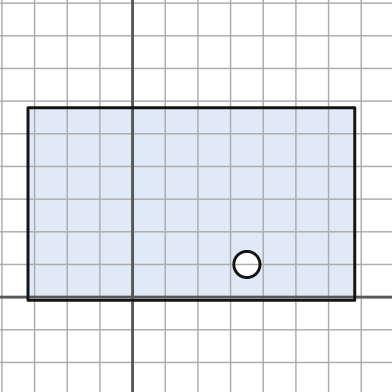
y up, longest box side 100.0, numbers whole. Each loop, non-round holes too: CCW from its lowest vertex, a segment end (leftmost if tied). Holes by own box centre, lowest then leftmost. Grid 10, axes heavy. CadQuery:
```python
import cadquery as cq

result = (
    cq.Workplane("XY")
    .moveTo(-32.0, -1.0)
    .lineTo(68.0, -1.0)
    .lineTo(68.0, 58.0)
    .lineTo(-32.0, 58.0)
    .close()
    .moveTo(35.0, 10.0)
    .circle(4.0)
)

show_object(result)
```